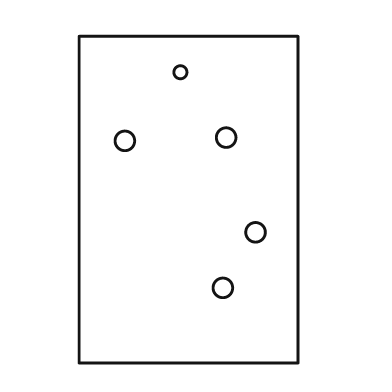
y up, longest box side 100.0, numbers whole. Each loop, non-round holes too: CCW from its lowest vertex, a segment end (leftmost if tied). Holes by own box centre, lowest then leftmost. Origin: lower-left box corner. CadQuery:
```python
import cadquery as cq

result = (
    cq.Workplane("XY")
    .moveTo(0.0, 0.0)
    .lineTo(67.0, 0.0)
    .lineTo(67.0, 100.0)
    .lineTo(0.0, 100.0)
    .close()
    .moveTo(44.0, 23.0)
    .circle(3.0)
    .moveTo(54.0, 40.0)
    .circle(3.0)
    .moveTo(14.0, 68.0)
    .circle(3.0)
    .moveTo(45.0, 69.0)
    .circle(3.0)
    .moveTo(31.0, 89.0)
    .circle(2.0)
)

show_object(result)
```